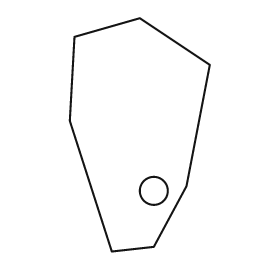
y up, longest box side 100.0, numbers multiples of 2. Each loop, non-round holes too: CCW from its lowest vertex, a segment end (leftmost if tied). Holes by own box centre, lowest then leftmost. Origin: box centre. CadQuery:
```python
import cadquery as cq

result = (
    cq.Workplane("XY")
    .moveTo(-12.0, -50.0)
    .lineTo(6.0, -48.0)
    .lineTo(20.0, -22.0)
    .lineTo(30.0, 30.0)
    .lineTo(0.0, 50.0)
    .lineTo(-28.0, 42.0)
    .lineTo(-30.0, 6.0)
    .close()
    .moveTo(6.0, -24.0)
    .circle(6.0)
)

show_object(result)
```